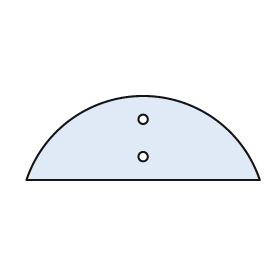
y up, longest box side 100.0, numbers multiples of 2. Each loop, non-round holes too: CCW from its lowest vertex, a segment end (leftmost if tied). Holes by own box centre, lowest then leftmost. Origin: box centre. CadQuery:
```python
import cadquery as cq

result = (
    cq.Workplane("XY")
    .moveTo(-50.0, -18.0)
    .lineTo(50.0, -18.0)
    .threePointArc((0.0, 18.0), (-50.0, -18.0))
    .close()
    .moveTo(0.0, -8.0)
    .circle(2.0)
    .moveTo(0.0, 8.0)
    .circle(2.0)
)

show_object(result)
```